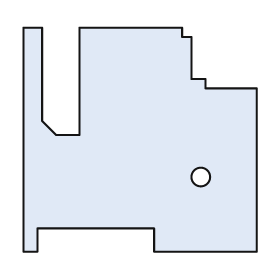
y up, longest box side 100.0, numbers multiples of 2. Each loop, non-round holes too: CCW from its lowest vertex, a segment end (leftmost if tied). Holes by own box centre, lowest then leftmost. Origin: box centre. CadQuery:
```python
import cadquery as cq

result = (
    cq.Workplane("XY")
    .moveTo(-50.0, -48.0)
    .lineTo(-44.0, -48.0)
    .lineTo(-44.0, -38.0)
    .lineTo(6.0, -38.0)
    .lineTo(6.0, -48.0)
    .lineTo(50.0, -48.0)
    .lineTo(50.0, 22.0)
    .lineTo(28.0, 22.0)
    .lineTo(28.0, 26.0)
    .lineTo(22.0, 26.0)
    .lineTo(22.0, 44.0)
    .lineTo(18.0, 44.0)
    .lineTo(18.0, 48.0)
    .lineTo(-26.0, 48.0)
    .lineTo(-26.0, 2.0)
    .lineTo(-36.0, 2.0)
    .lineTo(-42.0, 8.0)
    .lineTo(-42.0, 48.0)
    .lineTo(-50.0, 48.0)
    .close()
    .moveTo(26.0, -16.0)
    .circle(4.0)
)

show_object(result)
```